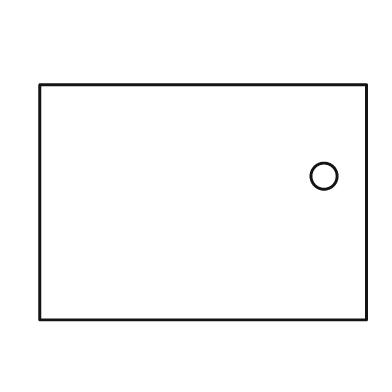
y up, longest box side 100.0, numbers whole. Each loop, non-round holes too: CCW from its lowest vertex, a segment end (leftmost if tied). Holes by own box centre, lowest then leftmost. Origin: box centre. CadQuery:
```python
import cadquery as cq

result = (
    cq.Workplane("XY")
    .moveTo(-50.0, -36.0)
    .lineTo(50.0, -36.0)
    .lineTo(50.0, 36.0)
    .lineTo(-50.0, 36.0)
    .close()
    .moveTo(37.0, 8.0)
    .circle(4.0)
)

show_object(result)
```